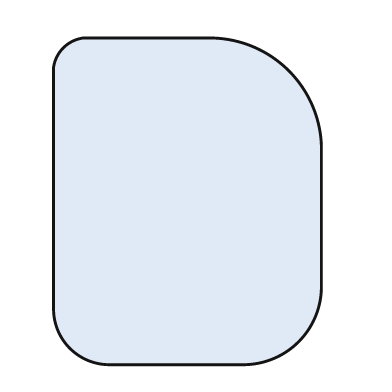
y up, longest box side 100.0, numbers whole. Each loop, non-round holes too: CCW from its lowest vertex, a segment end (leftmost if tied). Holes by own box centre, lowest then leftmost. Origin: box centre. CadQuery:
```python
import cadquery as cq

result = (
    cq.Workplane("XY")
    .moveTo(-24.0, -50.0)
    .lineTo(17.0, -50.0)
    .threePointArc((34.0, -43.0), (41.0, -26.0))
    .lineTo(41.0, 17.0)
    .threePointArc((31.0, 40.0), (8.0, 50.0))
    .lineTo(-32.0, 50.0)
    .threePointArc((-38.0, 47.0), (-41.0, 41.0))
    .lineTo(-41.0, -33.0)
    .threePointArc((-36.0, -45.0), (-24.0, -50.0))
    .close()
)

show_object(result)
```